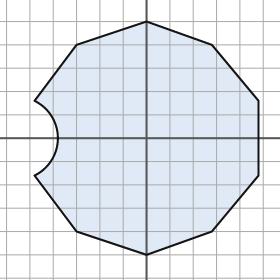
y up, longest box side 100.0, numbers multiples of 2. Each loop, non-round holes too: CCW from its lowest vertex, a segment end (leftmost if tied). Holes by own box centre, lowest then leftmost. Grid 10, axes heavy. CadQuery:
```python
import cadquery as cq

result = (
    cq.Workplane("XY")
    .moveTo(0.0, -50.0)
    .lineTo(28.0, -40.0)
    .lineTo(48.0, -16.0)
    .lineTo(48.0, 16.0)
    .lineTo(28.0, 40.0)
    .lineTo(0.0, 50.0)
    .lineTo(-30.0, 40.0)
    .lineTo(-48.0, 16.0)
    .threePointArc((-38.0, 0.0), (-48.0, -16.0))
    .lineTo(-30.0, -40.0)
    .close()
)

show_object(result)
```